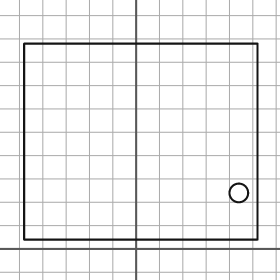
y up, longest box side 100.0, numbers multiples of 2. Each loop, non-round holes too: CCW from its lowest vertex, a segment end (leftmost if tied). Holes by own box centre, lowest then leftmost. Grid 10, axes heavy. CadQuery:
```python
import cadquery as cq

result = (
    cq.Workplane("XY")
    .moveTo(-48.0, 4.0)
    .lineTo(52.0, 4.0)
    .lineTo(52.0, 88.0)
    .lineTo(-48.0, 88.0)
    .close()
    .moveTo(44.0, 24.0)
    .circle(4.0)
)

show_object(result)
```